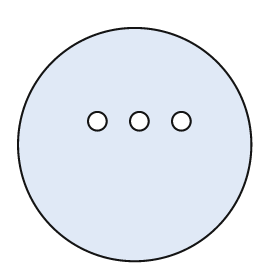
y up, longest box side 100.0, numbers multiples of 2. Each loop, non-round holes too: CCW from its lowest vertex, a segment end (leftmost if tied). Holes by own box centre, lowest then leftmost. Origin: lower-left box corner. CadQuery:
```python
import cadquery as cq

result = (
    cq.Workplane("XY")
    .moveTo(50.0, 50.0)
    .circle(50.0)
    .moveTo(34.0, 60.0)
    .circle(4.0)
    .moveTo(52.0, 60.0)
    .circle(4.0)
    .moveTo(70.0, 60.0)
    .circle(4.0)
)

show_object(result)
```